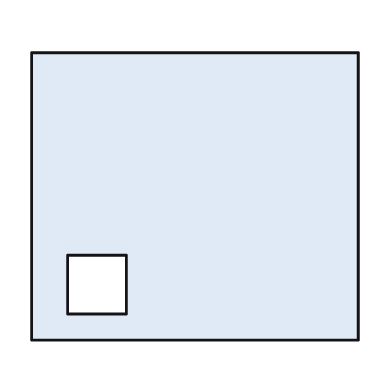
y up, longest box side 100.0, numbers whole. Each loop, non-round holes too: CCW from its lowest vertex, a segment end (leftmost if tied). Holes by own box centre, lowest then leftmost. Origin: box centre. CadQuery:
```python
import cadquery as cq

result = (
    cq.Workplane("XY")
    .moveTo(-50.0, -44.0)
    .lineTo(50.0, -44.0)
    .lineTo(50.0, 44.0)
    .lineTo(-50.0, 44.0)
    .close()
    .moveTo(-39.0, -36.0)
    .lineTo(-21.0, -36.0)
    .lineTo(-21.0, -18.0)
    .lineTo(-39.0, -18.0)
    .close()
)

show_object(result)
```